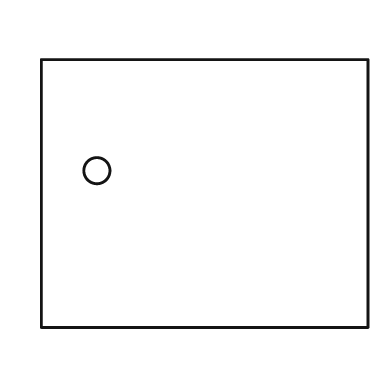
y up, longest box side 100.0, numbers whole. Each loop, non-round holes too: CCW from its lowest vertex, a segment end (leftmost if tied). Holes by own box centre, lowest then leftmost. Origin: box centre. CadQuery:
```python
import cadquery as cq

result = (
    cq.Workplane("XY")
    .moveTo(-50.0, -41.0)
    .lineTo(50.0, -41.0)
    .lineTo(50.0, 41.0)
    .lineTo(-50.0, 41.0)
    .close()
    .moveTo(-33.0, 7.0)
    .circle(4.0)
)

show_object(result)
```